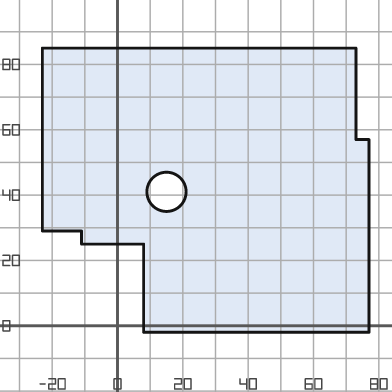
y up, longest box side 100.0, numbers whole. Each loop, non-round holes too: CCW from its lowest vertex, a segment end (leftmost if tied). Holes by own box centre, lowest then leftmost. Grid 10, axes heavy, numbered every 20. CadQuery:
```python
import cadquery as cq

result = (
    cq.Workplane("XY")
    .moveTo(8.0, -2.0)
    .lineTo(77.0, -2.0)
    .lineTo(77.0, 57.0)
    .lineTo(73.0, 57.0)
    .lineTo(73.0, 85.0)
    .lineTo(-23.0, 85.0)
    .lineTo(-23.0, 29.0)
    .lineTo(-11.0, 29.0)
    .lineTo(-11.0, 25.0)
    .lineTo(8.0, 25.0)
    .close()
    .moveTo(15.0, 41.0)
    .circle(6.0)
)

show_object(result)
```